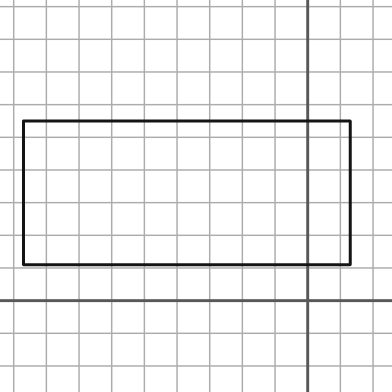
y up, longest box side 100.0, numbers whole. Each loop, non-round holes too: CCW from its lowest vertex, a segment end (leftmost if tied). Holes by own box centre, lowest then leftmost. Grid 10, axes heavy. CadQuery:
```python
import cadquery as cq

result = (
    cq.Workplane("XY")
    .moveTo(-87.0, 11.0)
    .lineTo(13.0, 11.0)
    .lineTo(13.0, 55.0)
    .lineTo(-87.0, 55.0)
    .close()
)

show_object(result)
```